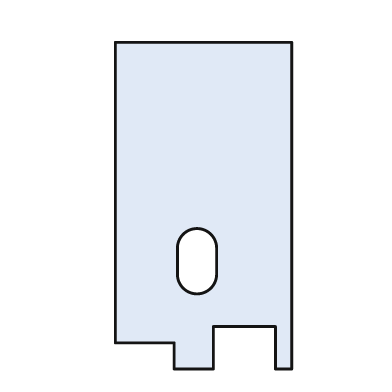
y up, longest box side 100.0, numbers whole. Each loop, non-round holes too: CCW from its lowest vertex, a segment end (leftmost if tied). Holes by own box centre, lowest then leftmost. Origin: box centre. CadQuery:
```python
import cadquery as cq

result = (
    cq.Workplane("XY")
    .moveTo(-9.0, -50.0)
    .lineTo(3.0, -50.0)
    .lineTo(3.0, -37.0)
    .lineTo(22.0, -37.0)
    .lineTo(22.0, -50.0)
    .lineTo(27.0, -50.0)
    .lineTo(27.0, 50.0)
    .lineTo(-27.0, 50.0)
    .lineTo(-27.0, -42.0)
    .lineTo(-9.0, -42.0)
    .close()
    .moveTo(-8.0, -21.0)
    .threePointArc((-2.0, -27.0), (4.0, -21.0))
    .lineTo(4.0, -13.0)
    .threePointArc((-2.0, -7.0), (-8.0, -13.0))
    .close()
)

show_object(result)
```